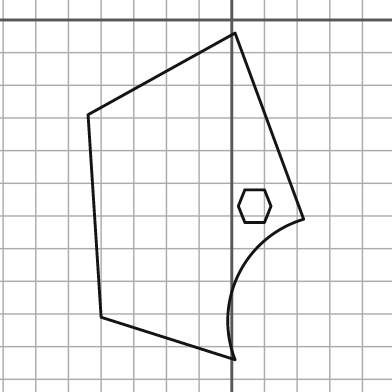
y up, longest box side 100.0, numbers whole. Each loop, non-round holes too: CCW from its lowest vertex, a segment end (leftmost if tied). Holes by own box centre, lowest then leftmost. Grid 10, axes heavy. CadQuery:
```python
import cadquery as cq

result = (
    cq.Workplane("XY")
    .moveTo(1.0, -104.0)
    .threePointArc((2.0, -78.0), (22.0, -61.0))
    .lineTo(1.0, -4.0)
    .lineTo(-44.0, -29.0)
    .lineTo(-40.0, -91.0)
    .close()
    .moveTo(4.0, -62.0)
    .lineTo(10.0, -62.0)
    .lineTo(12.0, -57.0)
    .lineTo(10.0, -52.0)
    .lineTo(4.0, -52.0)
    .lineTo(2.0, -57.0)
    .close()
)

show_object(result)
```